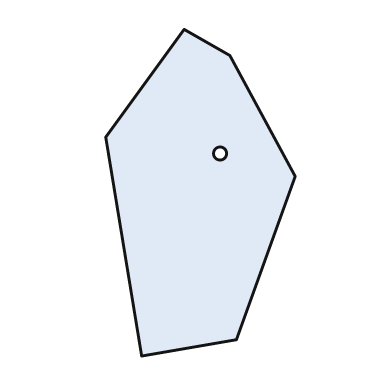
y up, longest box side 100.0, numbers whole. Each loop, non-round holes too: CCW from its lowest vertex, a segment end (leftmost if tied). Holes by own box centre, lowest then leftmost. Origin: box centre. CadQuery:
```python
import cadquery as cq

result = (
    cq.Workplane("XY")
    .moveTo(-18.0, -50.0)
    .lineTo(11.0, -45.0)
    .lineTo(29.0, 5.0)
    .lineTo(9.0, 42.0)
    .lineTo(-5.0, 50.0)
    .lineTo(-29.0, 17.0)
    .close()
    .moveTo(6.0, 12.0)
    .circle(2.0)
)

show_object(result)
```